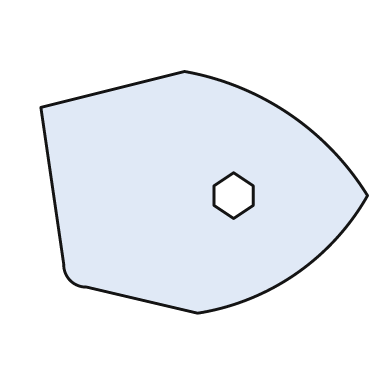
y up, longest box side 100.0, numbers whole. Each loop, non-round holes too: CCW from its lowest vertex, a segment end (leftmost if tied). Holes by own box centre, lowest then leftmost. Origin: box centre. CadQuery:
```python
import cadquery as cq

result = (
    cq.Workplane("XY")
    .moveTo(-2.0, -37.0)
    .threePointArc((28.0, -25.0), (50.0, -1.0))
    .threePointArc((26.0, 24.0), (-6.0, 37.0))
    .lineTo(-50.0, 26.0)
    .lineTo(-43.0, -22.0)
    .threePointArc((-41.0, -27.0), (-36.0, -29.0))
    .close()
    .moveTo(9.0, -8.0)
    .lineTo(15.0, -4.0)
    .lineTo(15.0, 2.0)
    .lineTo(9.0, 6.0)
    .lineTo(3.0, 2.0)
    .lineTo(3.0, -4.0)
    .close()
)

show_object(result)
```